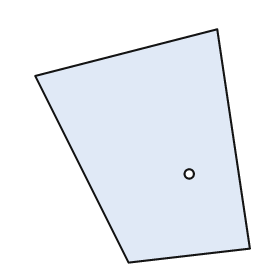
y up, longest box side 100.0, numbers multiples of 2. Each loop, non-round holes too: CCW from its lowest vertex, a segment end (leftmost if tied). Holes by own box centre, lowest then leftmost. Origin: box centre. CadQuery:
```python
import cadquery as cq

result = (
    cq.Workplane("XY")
    .moveTo(-6.0, -50.0)
    .lineTo(46.0, -44.0)
    .lineTo(32.0, 50.0)
    .lineTo(-46.0, 30.0)
    .close()
    .moveTo(20.0, -12.0)
    .circle(2.0)
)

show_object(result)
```